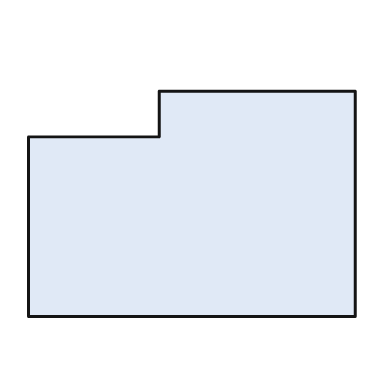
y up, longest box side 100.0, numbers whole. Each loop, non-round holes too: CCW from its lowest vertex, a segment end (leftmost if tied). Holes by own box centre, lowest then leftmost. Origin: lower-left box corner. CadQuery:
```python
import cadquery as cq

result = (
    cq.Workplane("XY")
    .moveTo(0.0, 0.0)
    .lineTo(100.0, 0.0)
    .lineTo(100.0, 69.0)
    .lineTo(40.0, 69.0)
    .lineTo(40.0, 55.0)
    .lineTo(0.0, 55.0)
    .close()
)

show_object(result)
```